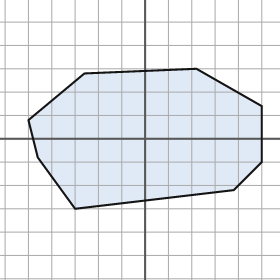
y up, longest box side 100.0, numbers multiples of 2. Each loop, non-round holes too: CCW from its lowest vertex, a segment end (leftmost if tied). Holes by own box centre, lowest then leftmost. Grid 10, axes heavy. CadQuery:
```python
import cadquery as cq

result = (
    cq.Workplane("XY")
    .moveTo(-30.0, -30.0)
    .lineTo(38.0, -22.0)
    .lineTo(50.0, -10.0)
    .lineTo(50.0, 14.0)
    .lineTo(22.0, 30.0)
    .lineTo(-26.0, 28.0)
    .lineTo(-50.0, 8.0)
    .lineTo(-46.0, -8.0)
    .close()
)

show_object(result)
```